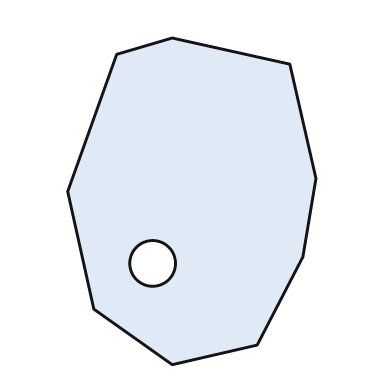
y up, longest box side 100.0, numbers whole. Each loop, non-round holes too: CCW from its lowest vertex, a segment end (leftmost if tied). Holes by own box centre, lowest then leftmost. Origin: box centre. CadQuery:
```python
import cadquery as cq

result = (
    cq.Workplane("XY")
    .moveTo(-6.0, -50.0)
    .lineTo(20.0, -44.0)
    .lineTo(34.0, -17.0)
    .lineTo(38.0, 7.0)
    .lineTo(30.0, 42.0)
    .lineTo(-6.0, 50.0)
    .lineTo(-23.0, 45.0)
    .lineTo(-38.0, 3.0)
    .lineTo(-30.0, -33.0)
    .close()
    .moveTo(-12.0, -19.0)
    .circle(7.0)
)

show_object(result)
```